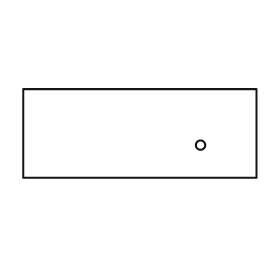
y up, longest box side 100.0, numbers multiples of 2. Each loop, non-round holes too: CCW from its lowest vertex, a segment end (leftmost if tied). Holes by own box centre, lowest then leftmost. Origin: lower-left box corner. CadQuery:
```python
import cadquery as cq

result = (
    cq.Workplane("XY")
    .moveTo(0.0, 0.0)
    .lineTo(100.0, 0.0)
    .lineTo(100.0, 38.0)
    .lineTo(0.0, 38.0)
    .close()
    .moveTo(76.0, 14.0)
    .circle(2.0)
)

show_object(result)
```